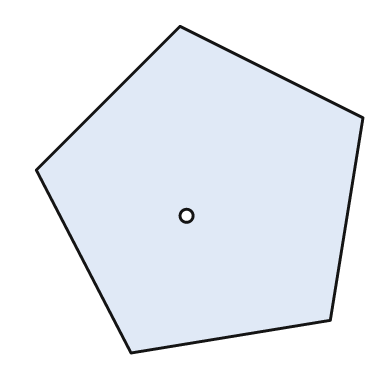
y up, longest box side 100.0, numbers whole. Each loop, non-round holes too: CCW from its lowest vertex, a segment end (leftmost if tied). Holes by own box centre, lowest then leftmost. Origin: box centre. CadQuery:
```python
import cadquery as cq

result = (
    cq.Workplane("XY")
    .moveTo(-21.0, -50.0)
    .lineTo(40.0, -40.0)
    .lineTo(50.0, 22.0)
    .lineTo(-6.0, 50.0)
    .lineTo(-50.0, 6.0)
    .close()
    .moveTo(-4.0, -8.0)
    .circle(2.0)
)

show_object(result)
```